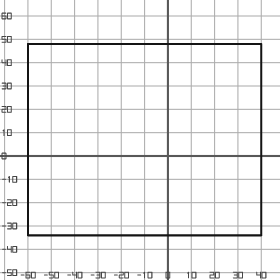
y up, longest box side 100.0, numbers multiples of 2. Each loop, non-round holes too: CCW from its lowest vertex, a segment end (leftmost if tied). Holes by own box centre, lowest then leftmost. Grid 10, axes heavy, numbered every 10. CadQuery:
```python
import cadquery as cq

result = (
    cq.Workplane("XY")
    .moveTo(-60.0, -34.0)
    .lineTo(40.0, -34.0)
    .lineTo(40.0, 48.0)
    .lineTo(-60.0, 48.0)
    .close()
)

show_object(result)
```